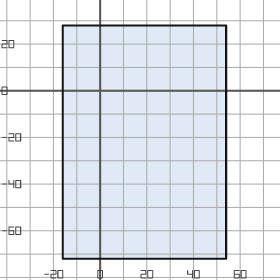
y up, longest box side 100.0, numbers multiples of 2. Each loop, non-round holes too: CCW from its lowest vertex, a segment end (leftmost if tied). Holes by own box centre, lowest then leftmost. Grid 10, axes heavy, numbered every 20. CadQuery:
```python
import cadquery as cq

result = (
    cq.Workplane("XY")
    .moveTo(-16.0, -72.0)
    .lineTo(54.0, -72.0)
    .lineTo(54.0, 28.0)
    .lineTo(-16.0, 28.0)
    .close()
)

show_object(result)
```